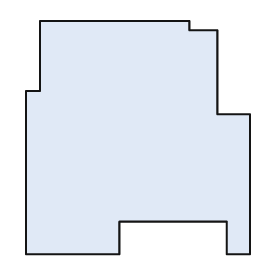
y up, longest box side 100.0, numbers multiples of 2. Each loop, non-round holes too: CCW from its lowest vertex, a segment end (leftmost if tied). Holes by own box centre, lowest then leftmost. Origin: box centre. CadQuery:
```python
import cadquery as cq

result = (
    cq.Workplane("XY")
    .moveTo(-48.0, -50.0)
    .lineTo(-8.0, -50.0)
    .lineTo(-8.0, -36.0)
    .lineTo(38.0, -36.0)
    .lineTo(38.0, -50.0)
    .lineTo(48.0, -50.0)
    .lineTo(48.0, 10.0)
    .lineTo(34.0, 10.0)
    .lineTo(34.0, 46.0)
    .lineTo(22.0, 46.0)
    .lineTo(22.0, 50.0)
    .lineTo(-42.0, 50.0)
    .lineTo(-42.0, 20.0)
    .lineTo(-48.0, 20.0)
    .close()
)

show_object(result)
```